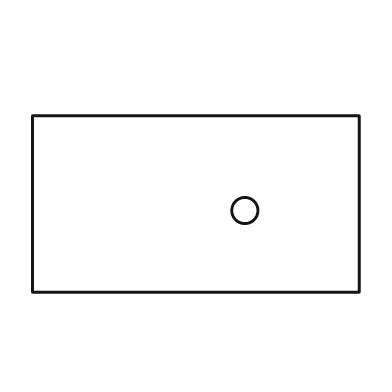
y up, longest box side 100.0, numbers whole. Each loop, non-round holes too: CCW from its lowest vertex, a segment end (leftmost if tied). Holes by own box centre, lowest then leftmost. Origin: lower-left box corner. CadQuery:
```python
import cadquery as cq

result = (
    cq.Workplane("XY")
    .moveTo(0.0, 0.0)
    .lineTo(100.0, 0.0)
    .lineTo(100.0, 54.0)
    .lineTo(0.0, 54.0)
    .close()
    .moveTo(65.0, 25.0)
    .circle(4.0)
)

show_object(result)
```